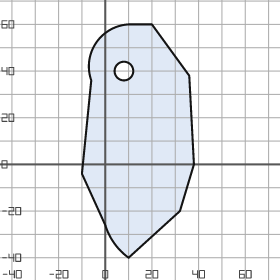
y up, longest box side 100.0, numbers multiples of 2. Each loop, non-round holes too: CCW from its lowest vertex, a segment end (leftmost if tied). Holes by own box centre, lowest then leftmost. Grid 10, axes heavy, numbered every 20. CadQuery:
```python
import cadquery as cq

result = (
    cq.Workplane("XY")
    .moveTo(10.0, -40.0)
    .lineTo(32.0, -20.0)
    .lineTo(38.0, 0.0)
    .lineTo(36.0, 38.0)
    .lineTo(20.0, 60.0)
    .lineTo(10.0, 60.0)
    .threePointArc((-4.0, 52.0), (-6.0, 36.0))
    .lineTo(-10.0, -4.0)
    .lineTo(0.0, -26.0)
    .threePointArc((4.0, -34.0), (10.0, -40.0))
    .close()
    .moveTo(8.0, 40.0)
    .circle(4.0)
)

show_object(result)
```